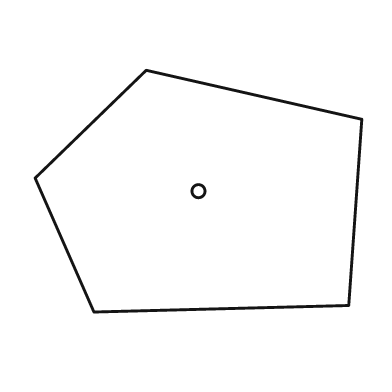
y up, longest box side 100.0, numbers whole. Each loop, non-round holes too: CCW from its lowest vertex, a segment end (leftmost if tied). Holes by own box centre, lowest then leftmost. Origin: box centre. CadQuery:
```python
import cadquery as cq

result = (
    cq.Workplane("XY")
    .moveTo(-32.0, -37.0)
    .lineTo(46.0, -35.0)
    .lineTo(50.0, 22.0)
    .lineTo(-16.0, 37.0)
    .lineTo(-50.0, 4.0)
    .close()
    .moveTo(0.0, 0.0)
    .circle(2.0)
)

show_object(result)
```